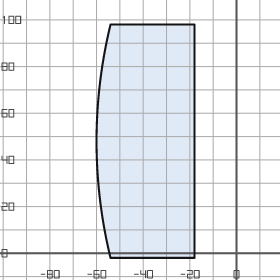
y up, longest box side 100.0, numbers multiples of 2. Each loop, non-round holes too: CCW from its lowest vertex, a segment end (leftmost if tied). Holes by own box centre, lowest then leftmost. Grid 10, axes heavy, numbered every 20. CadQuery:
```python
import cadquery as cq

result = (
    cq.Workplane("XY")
    .moveTo(-54.0, -2.0)
    .lineTo(-18.0, -2.0)
    .lineTo(-18.0, 98.0)
    .lineTo(-54.0, 98.0)
    .threePointArc((-60.0, 48.0), (-54.0, -2.0))
    .close()
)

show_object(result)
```